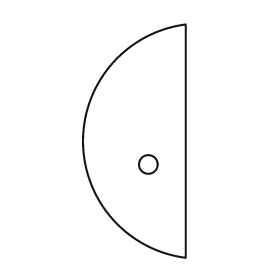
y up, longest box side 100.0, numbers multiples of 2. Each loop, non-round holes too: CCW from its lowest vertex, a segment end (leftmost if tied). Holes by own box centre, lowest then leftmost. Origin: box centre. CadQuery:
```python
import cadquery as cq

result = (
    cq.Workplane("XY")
    .moveTo(22.0, -50.0)
    .lineTo(22.0, 50.0)
    .threePointArc((-22.0, 0.0), (22.0, -50.0))
    .close()
    .moveTo(6.0, -10.0)
    .circle(4.0)
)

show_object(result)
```